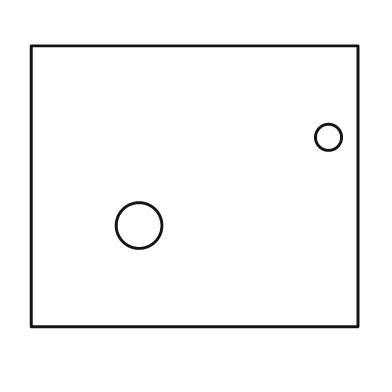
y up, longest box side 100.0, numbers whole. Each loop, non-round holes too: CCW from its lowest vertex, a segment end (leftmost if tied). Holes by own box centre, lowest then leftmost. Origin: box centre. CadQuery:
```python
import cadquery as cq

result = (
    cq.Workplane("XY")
    .moveTo(-50.0, -43.0)
    .lineTo(50.0, -43.0)
    .lineTo(50.0, 43.0)
    .lineTo(-50.0, 43.0)
    .close()
    .moveTo(-17.0, -12.0)
    .circle(7.0)
    .moveTo(41.0, 15.0)
    .circle(4.0)
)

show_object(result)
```